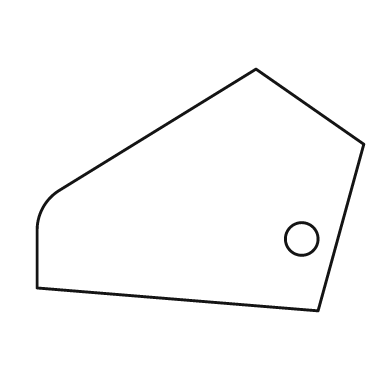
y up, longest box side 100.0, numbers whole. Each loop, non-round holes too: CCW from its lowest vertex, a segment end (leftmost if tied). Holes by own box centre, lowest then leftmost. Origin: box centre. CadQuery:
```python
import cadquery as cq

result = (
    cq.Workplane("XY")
    .moveTo(36.0, -37.0)
    .lineTo(50.0, 14.0)
    .lineTo(17.0, 37.0)
    .lineTo(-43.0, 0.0)
    .threePointArc((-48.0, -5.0), (-50.0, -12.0))
    .lineTo(-50.0, -30.0)
    .close()
    .moveTo(31.0, -15.0)
    .circle(5.0)
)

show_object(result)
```